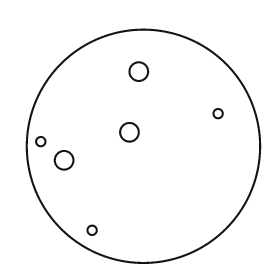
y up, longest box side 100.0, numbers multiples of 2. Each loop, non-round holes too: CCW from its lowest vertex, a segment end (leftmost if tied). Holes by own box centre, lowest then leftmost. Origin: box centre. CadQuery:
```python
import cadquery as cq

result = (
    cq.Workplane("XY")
    .moveTo(0.0, 0.0)
    .circle(50.0)
    .moveTo(-22.0, -36.0)
    .circle(2.0)
    .moveTo(-34.0, -6.0)
    .circle(4.0)
    .moveTo(-44.0, 2.0)
    .circle(2.0)
    .moveTo(-6.0, 6.0)
    .circle(4.0)
    .moveTo(32.0, 14.0)
    .circle(2.0)
    .moveTo(-2.0, 32.0)
    .circle(4.0)
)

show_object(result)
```